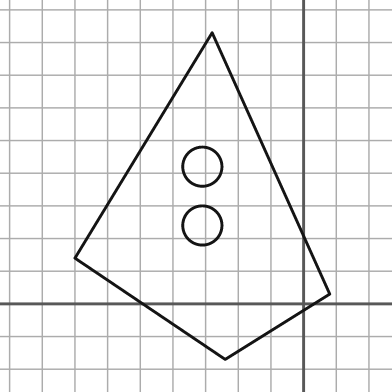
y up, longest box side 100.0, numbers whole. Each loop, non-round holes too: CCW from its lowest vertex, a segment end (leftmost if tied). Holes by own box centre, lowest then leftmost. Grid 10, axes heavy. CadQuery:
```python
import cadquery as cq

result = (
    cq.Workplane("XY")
    .moveTo(-24.0, -17.0)
    .lineTo(8.0, 3.0)
    .lineTo(-28.0, 83.0)
    .lineTo(-70.0, 14.0)
    .close()
    .moveTo(-31.0, 24.0)
    .circle(6.0)
    .moveTo(-31.0, 42.0)
    .circle(6.0)
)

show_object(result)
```